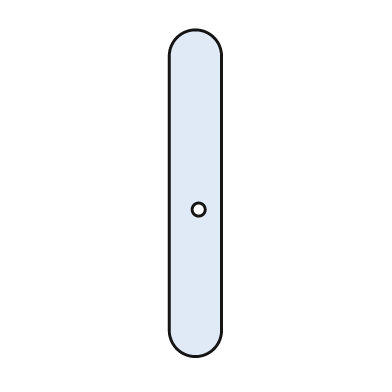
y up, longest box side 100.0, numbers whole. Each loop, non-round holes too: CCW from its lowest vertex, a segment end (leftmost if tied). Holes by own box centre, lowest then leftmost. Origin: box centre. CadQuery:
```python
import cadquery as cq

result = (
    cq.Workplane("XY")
    .moveTo(-8.0, -42.0)
    .threePointArc((0.0, -50.0), (8.0, -42.0))
    .lineTo(8.0, 42.0)
    .threePointArc((0.0, 50.0), (-8.0, 42.0))
    .close()
    .moveTo(1.0, -5.0)
    .circle(2.0)
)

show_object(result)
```